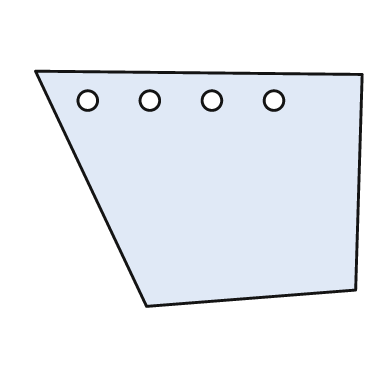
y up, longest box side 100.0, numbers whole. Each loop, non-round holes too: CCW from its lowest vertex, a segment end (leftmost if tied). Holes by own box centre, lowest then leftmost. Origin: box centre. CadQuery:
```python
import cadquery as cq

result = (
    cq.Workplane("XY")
    .moveTo(-16.0, -36.0)
    .lineTo(48.0, -31.0)
    .lineTo(50.0, 35.0)
    .lineTo(-50.0, 36.0)
    .close()
    .moveTo(-34.0, 27.0)
    .circle(3.0)
    .moveTo(-15.0, 27.0)
    .circle(3.0)
    .moveTo(4.0, 27.0)
    .circle(3.0)
    .moveTo(23.0, 27.0)
    .circle(3.0)
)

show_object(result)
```